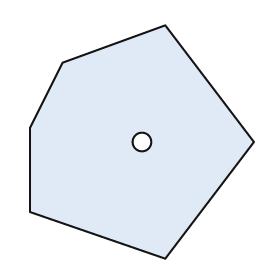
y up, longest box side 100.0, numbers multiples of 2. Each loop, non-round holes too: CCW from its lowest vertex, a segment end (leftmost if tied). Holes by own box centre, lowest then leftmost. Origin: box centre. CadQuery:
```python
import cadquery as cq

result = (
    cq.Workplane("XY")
    .moveTo(10.0, -50.0)
    .lineTo(48.0, 0.0)
    .lineTo(10.0, 50.0)
    .lineTo(-34.0, 34.0)
    .lineTo(-48.0, 6.0)
    .lineTo(-48.0, -30.0)
    .close()
    .moveTo(0.0, 0.0)
    .circle(4.0)
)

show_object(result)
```